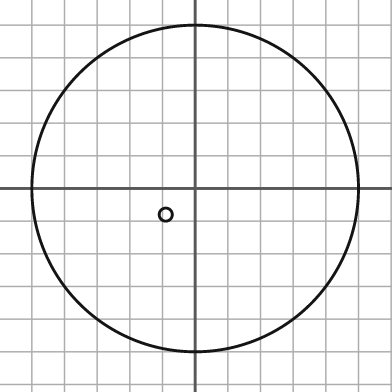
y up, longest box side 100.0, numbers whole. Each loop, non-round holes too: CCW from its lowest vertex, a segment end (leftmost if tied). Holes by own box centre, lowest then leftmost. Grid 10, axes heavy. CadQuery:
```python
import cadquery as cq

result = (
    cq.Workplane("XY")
    .moveTo(0.0, 0.0)
    .circle(50.0)
    .moveTo(-9.0, -8.0)
    .circle(2.0)
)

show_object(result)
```